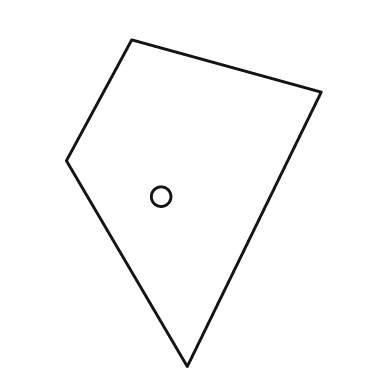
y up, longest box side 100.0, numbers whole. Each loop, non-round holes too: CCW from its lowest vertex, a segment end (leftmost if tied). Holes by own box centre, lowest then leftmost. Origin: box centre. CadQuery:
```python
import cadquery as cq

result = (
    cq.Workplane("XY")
    .moveTo(-2.0, -50.0)
    .lineTo(39.0, 34.0)
    .lineTo(-19.0, 50.0)
    .lineTo(-39.0, 13.0)
    .close()
    .moveTo(-10.0, 2.0)
    .circle(3.0)
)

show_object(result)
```